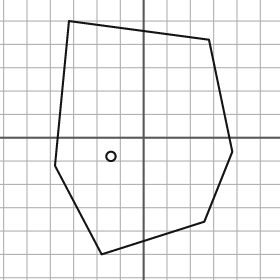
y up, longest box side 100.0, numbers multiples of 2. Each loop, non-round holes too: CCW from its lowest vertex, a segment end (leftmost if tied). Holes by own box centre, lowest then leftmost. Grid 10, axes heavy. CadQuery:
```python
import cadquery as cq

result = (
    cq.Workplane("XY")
    .moveTo(-18.0, -50.0)
    .lineTo(26.0, -36.0)
    .lineTo(38.0, -6.0)
    .lineTo(28.0, 42.0)
    .lineTo(-32.0, 50.0)
    .lineTo(-38.0, -12.0)
    .close()
    .moveTo(-14.0, -8.0)
    .circle(2.0)
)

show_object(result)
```